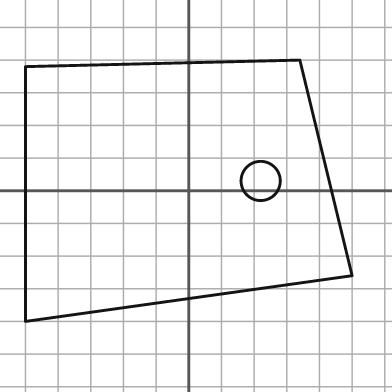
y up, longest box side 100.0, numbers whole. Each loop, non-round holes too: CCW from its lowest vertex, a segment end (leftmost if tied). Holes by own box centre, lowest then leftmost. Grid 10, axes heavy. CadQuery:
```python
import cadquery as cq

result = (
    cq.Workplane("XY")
    .moveTo(-50.0, -40.0)
    .lineTo(50.0, -26.0)
    .lineTo(34.0, 40.0)
    .lineTo(-50.0, 38.0)
    .close()
    .moveTo(22.0, 3.0)
    .circle(6.0)
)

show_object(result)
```